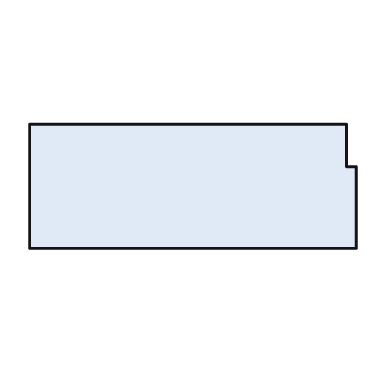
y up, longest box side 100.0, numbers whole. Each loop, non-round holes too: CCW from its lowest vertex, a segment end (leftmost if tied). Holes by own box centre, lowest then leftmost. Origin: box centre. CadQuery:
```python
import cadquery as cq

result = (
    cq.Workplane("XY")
    .moveTo(-50.0, -19.0)
    .lineTo(50.0, -19.0)
    .lineTo(50.0, 6.0)
    .lineTo(47.0, 6.0)
    .lineTo(47.0, 19.0)
    .lineTo(-50.0, 19.0)
    .close()
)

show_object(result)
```